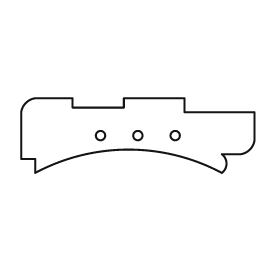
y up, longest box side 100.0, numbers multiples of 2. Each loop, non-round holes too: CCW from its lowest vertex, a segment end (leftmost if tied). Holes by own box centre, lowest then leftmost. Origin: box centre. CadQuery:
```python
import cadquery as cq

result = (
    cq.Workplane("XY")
    .moveTo(-44.0, -16.0)
    .threePointArc((-4.0, -6.0), (36.0, -16.0))
    .threePointArc((38.0, -12.0), (36.0, -8.0))
    .lineTo(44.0, -8.0)
    .threePointArc((48.0, -6.0), (50.0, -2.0))
    .lineTo(50.0, 10.0)
    .lineTo(20.0, 10.0)
    .lineTo(20.0, 16.0)
    .lineTo(-6.0, 16.0)
    .lineTo(-6.0, 12.0)
    .lineTo(-28.0, 12.0)
    .lineTo(-28.0, 16.0)
    .lineTo(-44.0, 16.0)
    .threePointArc((-48.0, 14.0), (-50.0, 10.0))
    .lineTo(-50.0, -10.0)
    .lineTo(-44.0, -10.0)
    .close()
    .moveTo(-16.0, 0.0)
    .circle(2.0)
    .moveTo(0.0, 0.0)
    .circle(2.0)
    .moveTo(16.0, 0.0)
    .circle(2.0)
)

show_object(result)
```